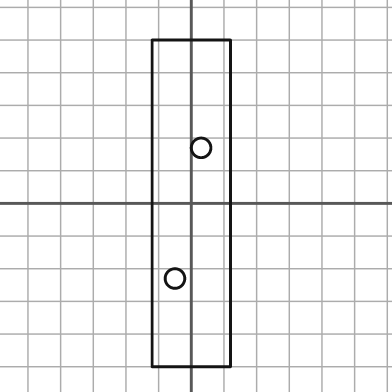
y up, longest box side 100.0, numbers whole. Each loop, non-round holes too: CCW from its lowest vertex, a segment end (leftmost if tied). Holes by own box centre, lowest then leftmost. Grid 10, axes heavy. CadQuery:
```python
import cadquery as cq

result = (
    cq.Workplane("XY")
    .moveTo(-12.0, -50.0)
    .lineTo(12.0, -50.0)
    .lineTo(12.0, 50.0)
    .lineTo(-12.0, 50.0)
    .close()
    .moveTo(-5.0, -23.0)
    .circle(3.0)
    .moveTo(3.0, 17.0)
    .circle(3.0)
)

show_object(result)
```